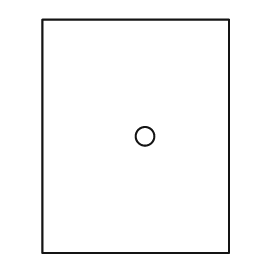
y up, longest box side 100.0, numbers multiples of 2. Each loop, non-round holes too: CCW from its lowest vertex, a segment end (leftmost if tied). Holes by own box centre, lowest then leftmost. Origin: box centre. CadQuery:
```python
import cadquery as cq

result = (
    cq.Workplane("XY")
    .moveTo(-40.0, -50.0)
    .lineTo(40.0, -50.0)
    .lineTo(40.0, 50.0)
    .lineTo(-40.0, 50.0)
    .close()
    .moveTo(4.0, 0.0)
    .circle(4.0)
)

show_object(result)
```